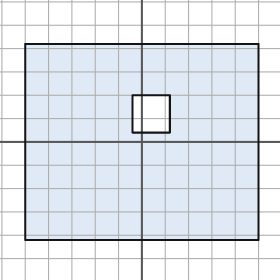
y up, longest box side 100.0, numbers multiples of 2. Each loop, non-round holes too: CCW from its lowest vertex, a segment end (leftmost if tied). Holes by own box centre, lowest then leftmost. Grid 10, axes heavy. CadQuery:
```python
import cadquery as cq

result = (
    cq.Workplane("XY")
    .moveTo(-50.0, -42.0)
    .lineTo(50.0, -42.0)
    .lineTo(50.0, 42.0)
    .lineTo(-50.0, 42.0)
    .close()
    .moveTo(-4.0, 4.0)
    .lineTo(12.0, 4.0)
    .lineTo(12.0, 20.0)
    .lineTo(-4.0, 20.0)
    .close()
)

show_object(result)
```